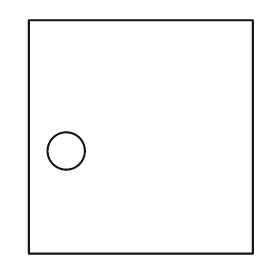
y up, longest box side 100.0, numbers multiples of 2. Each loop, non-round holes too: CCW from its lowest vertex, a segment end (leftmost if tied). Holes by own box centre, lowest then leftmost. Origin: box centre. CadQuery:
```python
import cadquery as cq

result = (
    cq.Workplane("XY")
    .moveTo(-48.0, -50.0)
    .lineTo(48.0, -50.0)
    .lineTo(48.0, 50.0)
    .lineTo(-48.0, 50.0)
    .close()
    .moveTo(-32.0, -6.0)
    .circle(8.0)
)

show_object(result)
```